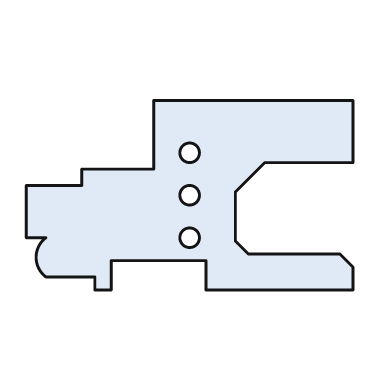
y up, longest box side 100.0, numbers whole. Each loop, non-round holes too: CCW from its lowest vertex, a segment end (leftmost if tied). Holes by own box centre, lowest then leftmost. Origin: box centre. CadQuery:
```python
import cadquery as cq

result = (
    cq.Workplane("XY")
    .moveTo(-29.0, -29.0)
    .lineTo(-24.0, -29.0)
    .lineTo(-24.0, -20.0)
    .lineTo(5.0, -20.0)
    .lineTo(5.0, -29.0)
    .lineTo(50.0, -29.0)
    .lineTo(50.0, -22.0)
    .lineTo(46.0, -18.0)
    .lineTo(18.0, -18.0)
    .lineTo(14.0, -14.0)
    .lineTo(14.0, 1.0)
    .lineTo(23.0, 10.0)
    .lineTo(50.0, 10.0)
    .lineTo(50.0, 29.0)
    .lineTo(-11.0, 29.0)
    .lineTo(-11.0, 8.0)
    .lineTo(-33.0, 8.0)
    .lineTo(-33.0, 3.0)
    .lineTo(-50.0, 3.0)
    .lineTo(-50.0, -13.0)
    .lineTo(-44.0, -13.0)
    .threePointArc((-47.0, -19.0), (-44.0, -25.0))
    .lineTo(-29.0, -25.0)
    .close()
    .moveTo(0.0, -13.0)
    .circle(3.0)
    .moveTo(0.0, 0.0)
    .circle(3.0)
    .moveTo(0.0, 13.0)
    .circle(3.0)
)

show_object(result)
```